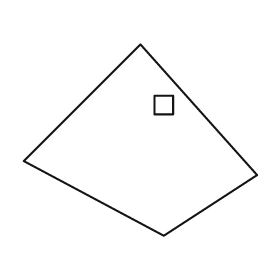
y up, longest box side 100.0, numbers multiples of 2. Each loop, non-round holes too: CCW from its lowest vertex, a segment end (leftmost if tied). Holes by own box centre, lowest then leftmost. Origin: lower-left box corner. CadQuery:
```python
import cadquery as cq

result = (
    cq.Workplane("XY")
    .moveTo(60.0, 0.0)
    .lineTo(100.0, 26.0)
    .lineTo(50.0, 82.0)
    .lineTo(0.0, 32.0)
    .close()
    .moveTo(56.0, 52.0)
    .lineTo(64.0, 52.0)
    .lineTo(64.0, 60.0)
    .lineTo(56.0, 60.0)
    .close()
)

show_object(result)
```